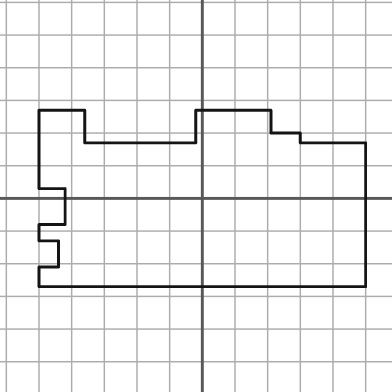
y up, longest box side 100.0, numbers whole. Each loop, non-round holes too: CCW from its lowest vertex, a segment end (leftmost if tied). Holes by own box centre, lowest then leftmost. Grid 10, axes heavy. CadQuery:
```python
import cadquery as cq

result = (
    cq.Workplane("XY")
    .moveTo(-50.0, -27.0)
    .lineTo(50.0, -27.0)
    .lineTo(50.0, 17.0)
    .lineTo(30.0, 17.0)
    .lineTo(30.0, 20.0)
    .lineTo(21.0, 20.0)
    .lineTo(21.0, 27.0)
    .lineTo(-2.0, 27.0)
    .lineTo(-2.0, 17.0)
    .lineTo(-36.0, 17.0)
    .lineTo(-36.0, 27.0)
    .lineTo(-50.0, 27.0)
    .lineTo(-50.0, 3.0)
    .lineTo(-42.0, 3.0)
    .lineTo(-42.0, -8.0)
    .lineTo(-50.0, -8.0)
    .lineTo(-50.0, -13.0)
    .lineTo(-44.0, -13.0)
    .lineTo(-44.0, -21.0)
    .lineTo(-50.0, -21.0)
    .close()
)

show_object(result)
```